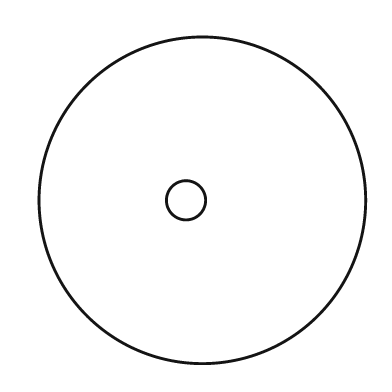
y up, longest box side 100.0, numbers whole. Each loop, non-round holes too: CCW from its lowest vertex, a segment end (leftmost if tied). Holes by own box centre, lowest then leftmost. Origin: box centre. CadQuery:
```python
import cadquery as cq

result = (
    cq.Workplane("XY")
    .moveTo(0.0, 0.0)
    .circle(50.0)
    .moveTo(-5.0, 0.0)
    .circle(6.0)
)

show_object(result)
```